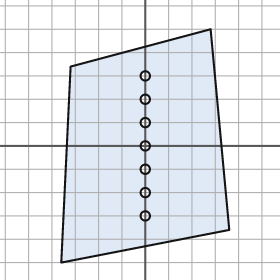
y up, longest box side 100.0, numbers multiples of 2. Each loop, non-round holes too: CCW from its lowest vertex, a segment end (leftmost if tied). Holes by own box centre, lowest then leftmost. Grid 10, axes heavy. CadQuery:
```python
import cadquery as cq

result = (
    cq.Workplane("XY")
    .moveTo(-36.0, -50.0)
    .lineTo(36.0, -36.0)
    .lineTo(28.0, 50.0)
    .lineTo(-32.0, 34.0)
    .close()
    .moveTo(0.0, -30.0)
    .circle(2.0)
    .moveTo(0.0, -20.0)
    .circle(2.0)
    .moveTo(0.0, -10.0)
    .circle(2.0)
    .moveTo(0.0, 0.0)
    .circle(2.0)
    .moveTo(0.0, 10.0)
    .circle(2.0)
    .moveTo(0.0, 20.0)
    .circle(2.0)
    .moveTo(0.0, 30.0)
    .circle(2.0)
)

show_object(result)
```